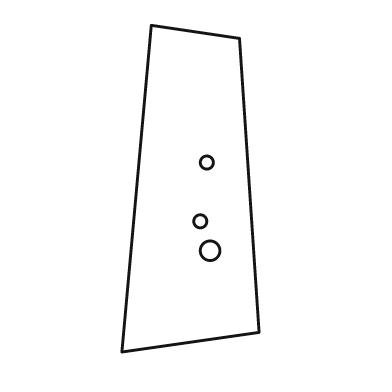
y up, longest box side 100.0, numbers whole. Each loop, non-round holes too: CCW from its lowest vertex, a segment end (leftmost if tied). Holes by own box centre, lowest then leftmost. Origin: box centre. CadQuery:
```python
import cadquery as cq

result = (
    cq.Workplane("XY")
    .moveTo(-21.0, -50.0)
    .lineTo(21.0, -44.0)
    .lineTo(15.0, 46.0)
    .lineTo(-12.0, 50.0)
    .close()
    .moveTo(6.0, -19.0)
    .circle(3.0)
    .moveTo(3.0, -10.0)
    .circle(2.0)
    .moveTo(5.0, 8.0)
    .circle(2.0)
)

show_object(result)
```